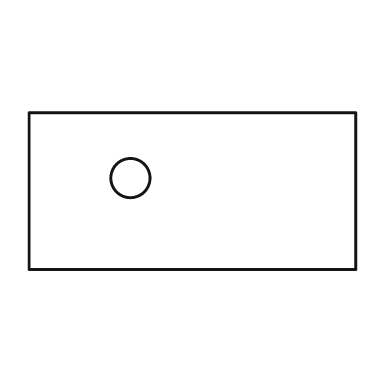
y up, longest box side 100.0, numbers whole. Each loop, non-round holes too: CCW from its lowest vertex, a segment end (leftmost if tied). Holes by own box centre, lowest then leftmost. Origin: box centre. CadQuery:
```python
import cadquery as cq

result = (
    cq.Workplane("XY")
    .moveTo(-50.0, -24.0)
    .lineTo(50.0, -24.0)
    .lineTo(50.0, 24.0)
    .lineTo(-50.0, 24.0)
    .close()
    .moveTo(-19.0, 4.0)
    .circle(6.0)
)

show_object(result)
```